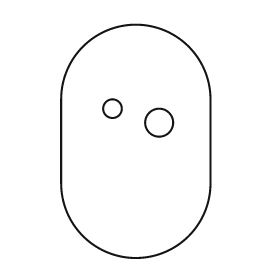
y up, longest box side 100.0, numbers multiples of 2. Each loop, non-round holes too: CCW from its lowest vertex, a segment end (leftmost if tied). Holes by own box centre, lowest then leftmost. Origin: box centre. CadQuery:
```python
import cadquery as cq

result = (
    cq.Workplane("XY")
    .moveTo(-32.0, -18.0)
    .threePointArc((0.0, -50.0), (32.0, -18.0))
    .lineTo(32.0, 18.0)
    .threePointArc((0.0, 50.0), (-32.0, 18.0))
    .close()
    .moveTo(10.0, 8.0)
    .circle(6.0)
    .moveTo(-10.0, 14.0)
    .circle(4.0)
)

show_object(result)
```